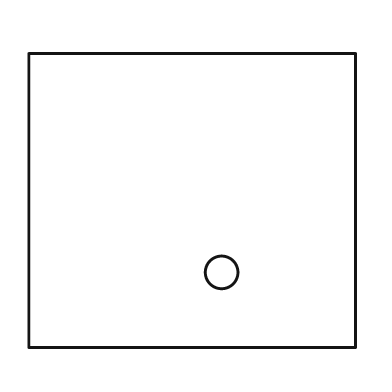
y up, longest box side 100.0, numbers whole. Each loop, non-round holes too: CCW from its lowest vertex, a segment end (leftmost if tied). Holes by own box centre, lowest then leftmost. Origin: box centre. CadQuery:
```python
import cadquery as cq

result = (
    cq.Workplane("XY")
    .moveTo(-50.0, -45.0)
    .lineTo(50.0, -45.0)
    .lineTo(50.0, 45.0)
    .lineTo(-50.0, 45.0)
    .close()
    .moveTo(9.0, -22.0)
    .circle(5.0)
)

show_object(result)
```